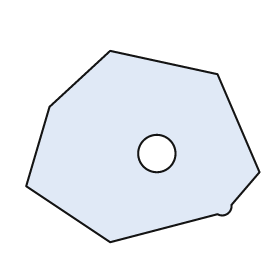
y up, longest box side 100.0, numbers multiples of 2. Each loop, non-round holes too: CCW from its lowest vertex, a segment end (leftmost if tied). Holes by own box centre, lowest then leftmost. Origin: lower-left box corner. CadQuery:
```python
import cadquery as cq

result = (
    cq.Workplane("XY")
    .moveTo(36.0, 0.0)
    .lineTo(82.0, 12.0)
    .threePointArc((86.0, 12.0), (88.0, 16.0))
    .lineTo(100.0, 30.0)
    .lineTo(82.0, 72.0)
    .lineTo(36.0, 82.0)
    .lineTo(10.0, 58.0)
    .lineTo(0.0, 24.0)
    .close()
    .moveTo(56.0, 38.0)
    .circle(8.0)
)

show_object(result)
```